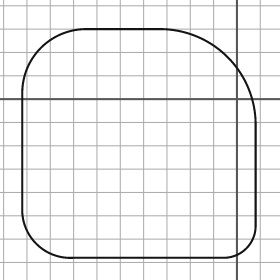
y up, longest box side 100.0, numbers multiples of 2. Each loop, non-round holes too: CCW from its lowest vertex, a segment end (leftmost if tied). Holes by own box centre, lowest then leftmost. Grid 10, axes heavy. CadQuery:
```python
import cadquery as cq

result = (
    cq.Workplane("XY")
    .moveTo(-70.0, -68.0)
    .lineTo(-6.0, -68.0)
    .threePointArc((4.0, -64.0), (8.0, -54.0))
    .lineTo(8.0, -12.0)
    .threePointArc((-4.0, 18.0), (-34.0, 30.0))
    .lineTo(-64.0, 30.0)
    .threePointArc((-84.0, 22.0), (-92.0, 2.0))
    .lineTo(-92.0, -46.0)
    .threePointArc((-86.0, -62.0), (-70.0, -68.0))
    .close()
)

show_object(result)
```